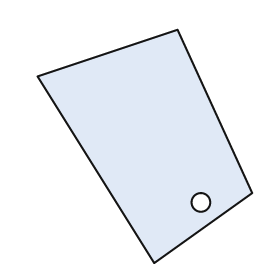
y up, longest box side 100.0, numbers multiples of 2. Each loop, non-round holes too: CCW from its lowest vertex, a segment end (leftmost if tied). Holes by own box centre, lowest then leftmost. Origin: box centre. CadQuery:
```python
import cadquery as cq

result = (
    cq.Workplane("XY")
    .moveTo(4.0, -50.0)
    .lineTo(46.0, -20.0)
    .lineTo(14.0, 50.0)
    .lineTo(-46.0, 30.0)
    .close()
    .moveTo(24.0, -24.0)
    .circle(4.0)
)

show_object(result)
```